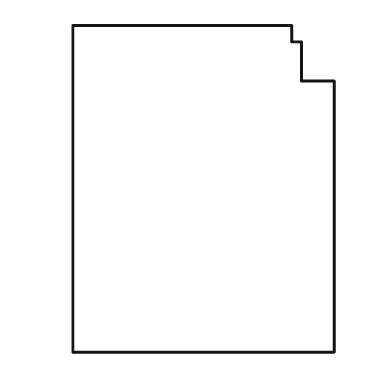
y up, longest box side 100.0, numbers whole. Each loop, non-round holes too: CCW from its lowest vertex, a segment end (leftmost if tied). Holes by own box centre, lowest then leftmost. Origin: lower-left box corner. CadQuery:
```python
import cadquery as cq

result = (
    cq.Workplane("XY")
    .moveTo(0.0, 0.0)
    .lineTo(80.0, 0.0)
    .lineTo(80.0, 83.0)
    .lineTo(70.0, 83.0)
    .lineTo(70.0, 95.0)
    .lineTo(67.0, 95.0)
    .lineTo(67.0, 100.0)
    .lineTo(0.0, 100.0)
    .close()
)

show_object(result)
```